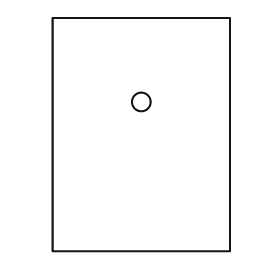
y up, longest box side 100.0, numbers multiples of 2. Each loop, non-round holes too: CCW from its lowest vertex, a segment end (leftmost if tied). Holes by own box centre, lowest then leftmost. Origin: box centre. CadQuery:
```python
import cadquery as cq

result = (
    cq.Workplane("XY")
    .moveTo(-38.0, -50.0)
    .lineTo(38.0, -50.0)
    .lineTo(38.0, 50.0)
    .lineTo(-38.0, 50.0)
    .close()
    .moveTo(0.0, 14.0)
    .circle(4.0)
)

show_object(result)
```